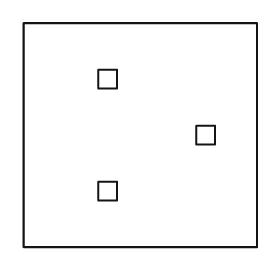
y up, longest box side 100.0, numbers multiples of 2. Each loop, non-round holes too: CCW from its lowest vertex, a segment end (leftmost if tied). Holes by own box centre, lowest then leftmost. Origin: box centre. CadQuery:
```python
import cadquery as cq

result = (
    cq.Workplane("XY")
    .moveTo(-50.0, -48.0)
    .lineTo(50.0, -48.0)
    .lineTo(50.0, 48.0)
    .lineTo(-50.0, 48.0)
    .close()
    .moveTo(-18.0, -28.0)
    .lineTo(-10.0, -28.0)
    .lineTo(-10.0, -20.0)
    .lineTo(-18.0, -20.0)
    .close()
    .moveTo(24.0, -4.0)
    .lineTo(32.0, -4.0)
    .lineTo(32.0, 4.0)
    .lineTo(24.0, 4.0)
    .close()
    .moveTo(-18.0, 20.0)
    .lineTo(-10.0, 20.0)
    .lineTo(-10.0, 28.0)
    .lineTo(-18.0, 28.0)
    .close()
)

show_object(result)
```